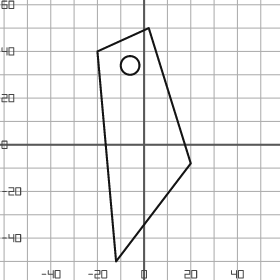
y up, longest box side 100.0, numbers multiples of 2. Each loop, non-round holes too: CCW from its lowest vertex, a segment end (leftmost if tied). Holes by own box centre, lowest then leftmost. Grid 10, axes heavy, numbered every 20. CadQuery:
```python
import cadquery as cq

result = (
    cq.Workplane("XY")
    .moveTo(-12.0, -50.0)
    .lineTo(20.0, -8.0)
    .lineTo(2.0, 50.0)
    .lineTo(-20.0, 40.0)
    .close()
    .moveTo(-6.0, 34.0)
    .circle(4.0)
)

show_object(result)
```